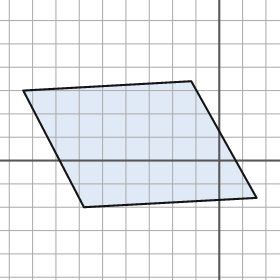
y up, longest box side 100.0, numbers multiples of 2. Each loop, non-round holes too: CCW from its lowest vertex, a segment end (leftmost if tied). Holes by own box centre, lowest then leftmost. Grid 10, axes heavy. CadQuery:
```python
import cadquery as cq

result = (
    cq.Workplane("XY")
    .moveTo(-58.0, -20.0)
    .lineTo(16.0, -16.0)
    .lineTo(-12.0, 34.0)
    .lineTo(-84.0, 30.0)
    .close()
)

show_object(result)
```